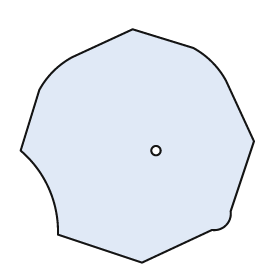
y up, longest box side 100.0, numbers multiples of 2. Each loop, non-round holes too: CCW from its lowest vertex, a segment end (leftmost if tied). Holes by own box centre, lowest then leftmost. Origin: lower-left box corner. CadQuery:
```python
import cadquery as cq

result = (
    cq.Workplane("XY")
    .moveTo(52.0, 0.0)
    .lineTo(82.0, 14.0)
    .threePointArc((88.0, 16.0), (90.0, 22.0))
    .lineTo(100.0, 52.0)
    .lineTo(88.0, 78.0)
    .threePointArc((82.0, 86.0), (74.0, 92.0))
    .lineTo(48.0, 100.0)
    .lineTo(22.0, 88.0)
    .threePointArc((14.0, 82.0), (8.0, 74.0))
    .lineTo(0.0, 48.0)
    .threePointArc((12.0, 32.0), (16.0, 12.0))
    .close()
    .moveTo(58.0, 48.0)
    .circle(2.0)
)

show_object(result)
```